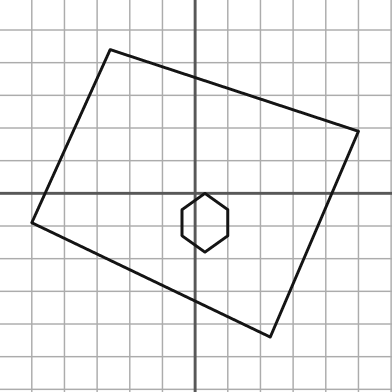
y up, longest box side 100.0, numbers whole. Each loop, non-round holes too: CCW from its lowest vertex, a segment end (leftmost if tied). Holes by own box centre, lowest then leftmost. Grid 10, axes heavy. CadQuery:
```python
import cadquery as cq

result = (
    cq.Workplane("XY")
    .moveTo(23.0, -44.0)
    .lineTo(50.0, 19.0)
    .lineTo(-26.0, 44.0)
    .lineTo(-50.0, -9.0)
    .close()
    .moveTo(3.0, -18.0)
    .lineTo(10.0, -13.0)
    .lineTo(10.0, -5.0)
    .lineTo(3.0, 0.0)
    .lineTo(-4.0, -5.0)
    .lineTo(-4.0, -13.0)
    .close()
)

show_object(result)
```